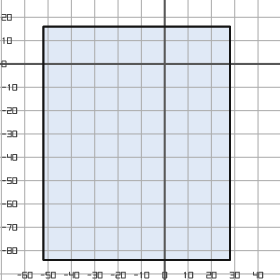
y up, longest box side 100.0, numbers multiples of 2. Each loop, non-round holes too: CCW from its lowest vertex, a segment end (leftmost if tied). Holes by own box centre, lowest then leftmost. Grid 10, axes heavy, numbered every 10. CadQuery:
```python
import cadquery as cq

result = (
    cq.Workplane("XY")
    .moveTo(-52.0, -84.0)
    .lineTo(28.0, -84.0)
    .lineTo(28.0, 16.0)
    .lineTo(-52.0, 16.0)
    .close()
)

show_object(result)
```